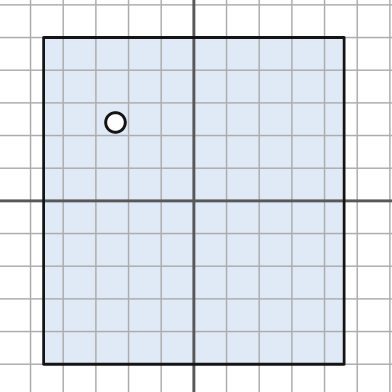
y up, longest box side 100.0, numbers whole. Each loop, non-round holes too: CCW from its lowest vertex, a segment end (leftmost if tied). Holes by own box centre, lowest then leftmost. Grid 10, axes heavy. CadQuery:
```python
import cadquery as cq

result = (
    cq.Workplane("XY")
    .moveTo(-46.0, -50.0)
    .lineTo(46.0, -50.0)
    .lineTo(46.0, 50.0)
    .lineTo(-46.0, 50.0)
    .close()
    .moveTo(-24.0, 24.0)
    .circle(3.0)
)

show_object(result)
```